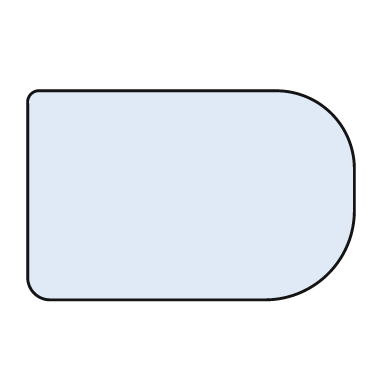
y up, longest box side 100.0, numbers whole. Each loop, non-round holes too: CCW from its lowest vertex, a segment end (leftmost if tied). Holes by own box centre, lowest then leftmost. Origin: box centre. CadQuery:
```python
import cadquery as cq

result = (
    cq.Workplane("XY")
    .moveTo(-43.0, -32.0)
    .lineTo(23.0, -32.0)
    .threePointArc((42.0, -24.0), (50.0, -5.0))
    .lineTo(50.0, 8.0)
    .threePointArc((43.0, 25.0), (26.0, 32.0))
    .lineTo(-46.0, 32.0)
    .threePointArc((-49.0, 31.0), (-50.0, 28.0))
    .lineTo(-50.0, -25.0)
    .threePointArc((-48.0, -30.0), (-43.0, -32.0))
    .close()
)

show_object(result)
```